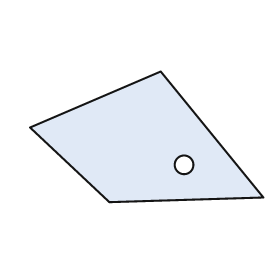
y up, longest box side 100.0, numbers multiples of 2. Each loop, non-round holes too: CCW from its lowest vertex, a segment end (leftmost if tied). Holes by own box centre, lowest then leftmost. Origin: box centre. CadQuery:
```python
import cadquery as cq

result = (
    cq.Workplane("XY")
    .moveTo(-16.0, -28.0)
    .lineTo(50.0, -26.0)
    .lineTo(6.0, 28.0)
    .lineTo(-50.0, 4.0)
    .close()
    .moveTo(16.0, -12.0)
    .circle(4.0)
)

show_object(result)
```